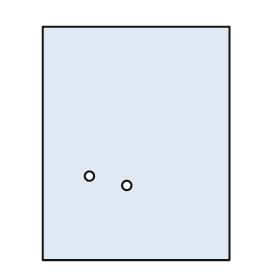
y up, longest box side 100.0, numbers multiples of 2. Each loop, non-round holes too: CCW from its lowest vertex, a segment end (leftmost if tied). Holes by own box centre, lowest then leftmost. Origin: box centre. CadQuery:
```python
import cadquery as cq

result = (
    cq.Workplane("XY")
    .moveTo(-40.0, -50.0)
    .lineTo(40.0, -50.0)
    .lineTo(40.0, 50.0)
    .lineTo(-40.0, 50.0)
    .close()
    .moveTo(-4.0, -18.0)
    .circle(2.0)
    .moveTo(-20.0, -14.0)
    .circle(2.0)
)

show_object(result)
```